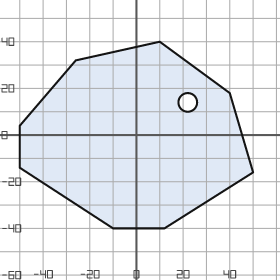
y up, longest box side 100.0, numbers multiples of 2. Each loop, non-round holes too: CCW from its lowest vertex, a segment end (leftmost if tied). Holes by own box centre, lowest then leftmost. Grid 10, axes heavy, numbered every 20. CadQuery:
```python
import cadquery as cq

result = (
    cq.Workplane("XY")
    .moveTo(-10.0, -40.0)
    .lineTo(12.0, -40.0)
    .lineTo(50.0, -16.0)
    .lineTo(40.0, 18.0)
    .lineTo(10.0, 40.0)
    .lineTo(-26.0, 32.0)
    .lineTo(-50.0, 4.0)
    .lineTo(-50.0, -14.0)
    .close()
    .moveTo(22.0, 14.0)
    .circle(4.0)
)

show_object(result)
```